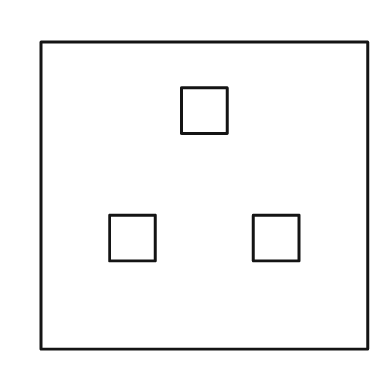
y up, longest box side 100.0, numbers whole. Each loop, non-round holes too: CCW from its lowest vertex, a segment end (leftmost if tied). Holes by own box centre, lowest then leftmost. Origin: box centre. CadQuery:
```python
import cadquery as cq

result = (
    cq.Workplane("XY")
    .moveTo(-50.0, -47.0)
    .lineTo(50.0, -47.0)
    .lineTo(50.0, 47.0)
    .lineTo(-50.0, 47.0)
    .close()
    .moveTo(-29.0, -20.0)
    .lineTo(-15.0, -20.0)
    .lineTo(-15.0, -6.0)
    .lineTo(-29.0, -6.0)
    .close()
    .moveTo(15.0, -20.0)
    .lineTo(29.0, -20.0)
    .lineTo(29.0, -6.0)
    .lineTo(15.0, -6.0)
    .close()
    .moveTo(-7.0, 19.0)
    .lineTo(7.0, 19.0)
    .lineTo(7.0, 33.0)
    .lineTo(-7.0, 33.0)
    .close()
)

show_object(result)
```